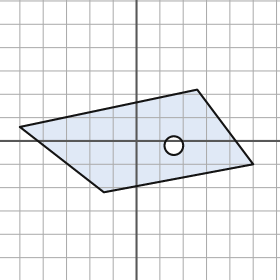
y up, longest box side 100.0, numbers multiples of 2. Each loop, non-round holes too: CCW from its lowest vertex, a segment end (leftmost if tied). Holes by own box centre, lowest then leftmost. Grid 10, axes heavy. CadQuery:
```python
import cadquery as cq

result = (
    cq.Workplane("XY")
    .moveTo(-14.0, -22.0)
    .lineTo(50.0, -10.0)
    .lineTo(26.0, 22.0)
    .lineTo(-50.0, 6.0)
    .close()
    .moveTo(16.0, -2.0)
    .circle(4.0)
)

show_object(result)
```